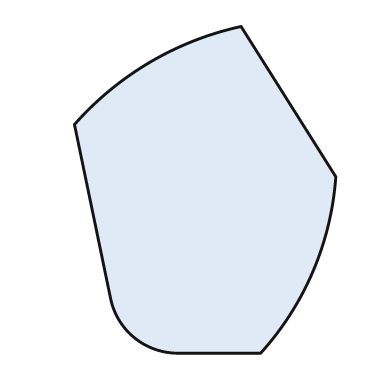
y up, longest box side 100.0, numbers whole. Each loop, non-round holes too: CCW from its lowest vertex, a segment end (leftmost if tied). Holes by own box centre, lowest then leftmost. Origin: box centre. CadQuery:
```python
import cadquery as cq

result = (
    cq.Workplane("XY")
    .moveTo(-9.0, -50.0)
    .lineTo(17.0, -50.0)
    .threePointArc((33.0, -25.0), (40.0, 4.0))
    .lineTo(11.0, 50.0)
    .threePointArc((-17.0, 39.0), (-40.0, 20.0))
    .lineTo(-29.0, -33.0)
    .threePointArc((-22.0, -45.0), (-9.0, -50.0))
    .close()
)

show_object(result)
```